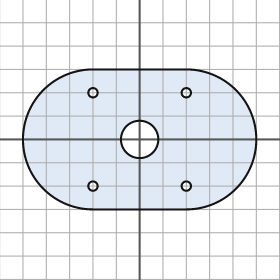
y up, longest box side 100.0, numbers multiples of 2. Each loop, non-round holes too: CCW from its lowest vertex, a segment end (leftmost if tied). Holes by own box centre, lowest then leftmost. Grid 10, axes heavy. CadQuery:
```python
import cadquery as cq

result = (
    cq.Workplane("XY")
    .moveTo(-20.0, -30.0)
    .lineTo(20.0, -30.0)
    .threePointArc((50.0, 0.0), (20.0, 30.0))
    .lineTo(-20.0, 30.0)
    .threePointArc((-50.0, 0.0), (-20.0, -30.0))
    .close()
    .moveTo(-20.0, -20.0)
    .circle(2.0)
    .moveTo(20.0, -20.0)
    .circle(2.0)
    .moveTo(0.0, 0.0)
    .circle(8.0)
    .moveTo(-20.0, 20.0)
    .circle(2.0)
    .moveTo(20.0, 20.0)
    .circle(2.0)
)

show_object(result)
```